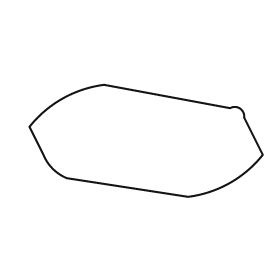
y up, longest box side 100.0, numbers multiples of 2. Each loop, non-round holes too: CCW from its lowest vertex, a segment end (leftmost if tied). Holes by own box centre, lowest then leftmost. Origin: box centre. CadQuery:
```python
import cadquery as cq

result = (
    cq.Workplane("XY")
    .moveTo(18.0, -24.0)
    .threePointArc((36.0, -18.0), (50.0, -6.0))
    .lineTo(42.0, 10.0)
    .threePointArc((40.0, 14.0), (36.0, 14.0))
    .lineTo(-18.0, 24.0)
    .threePointArc((-36.0, 18.0), (-50.0, 6.0))
    .lineTo(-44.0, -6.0)
    .threePointArc((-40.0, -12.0), (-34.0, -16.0))
    .close()
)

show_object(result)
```